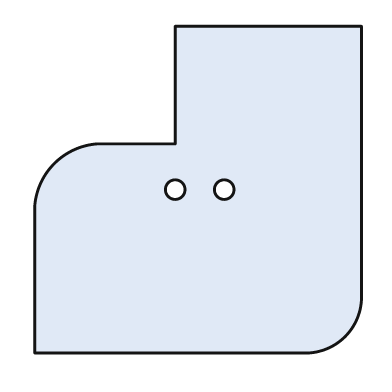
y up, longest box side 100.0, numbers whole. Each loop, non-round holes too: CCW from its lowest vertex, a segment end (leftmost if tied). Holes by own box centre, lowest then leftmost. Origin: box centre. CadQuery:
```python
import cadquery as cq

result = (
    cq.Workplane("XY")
    .moveTo(-50.0, -50.0)
    .lineTo(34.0, -50.0)
    .threePointArc((45.0, -45.0), (50.0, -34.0))
    .lineTo(50.0, 50.0)
    .lineTo(-7.0, 50.0)
    .lineTo(-7.0, 14.0)
    .lineTo(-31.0, 14.0)
    .threePointArc((-44.0, 8.0), (-50.0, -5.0))
    .close()
    .moveTo(-7.0, 0.0)
    .circle(3.0)
    .moveTo(8.0, 0.0)
    .circle(3.0)
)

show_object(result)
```